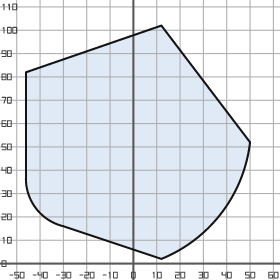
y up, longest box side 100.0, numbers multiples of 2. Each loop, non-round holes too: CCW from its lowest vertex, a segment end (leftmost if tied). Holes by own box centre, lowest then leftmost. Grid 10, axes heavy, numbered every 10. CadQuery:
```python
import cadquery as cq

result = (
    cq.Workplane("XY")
    .moveTo(12.0, 2.0)
    .threePointArc((38.0, 22.0), (50.0, 52.0))
    .lineTo(12.0, 102.0)
    .lineTo(-46.0, 82.0)
    .lineTo(-46.0, 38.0)
    .threePointArc((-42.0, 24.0), (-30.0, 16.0))
    .close()
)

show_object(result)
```